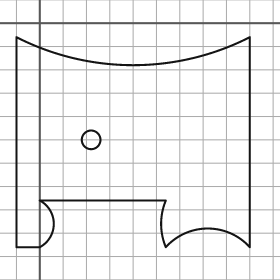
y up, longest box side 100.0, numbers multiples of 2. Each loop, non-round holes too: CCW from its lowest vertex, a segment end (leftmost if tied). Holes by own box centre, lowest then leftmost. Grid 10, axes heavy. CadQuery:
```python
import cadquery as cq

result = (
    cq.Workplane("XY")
    .moveTo(-10.0, -96.0)
    .lineTo(0.0, -96.0)
    .threePointArc((6.0, -86.0), (0.0, -76.0))
    .lineTo(54.0, -76.0)
    .threePointArc((52.0, -86.0), (54.0, -96.0))
    .threePointArc((72.0, -88.0), (90.0, -96.0))
    .lineTo(90.0, -6.0)
    .threePointArc((40.0, -18.0), (-10.0, -6.0))
    .close()
    .moveTo(22.0, -50.0)
    .circle(4.0)
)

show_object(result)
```